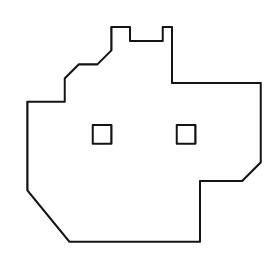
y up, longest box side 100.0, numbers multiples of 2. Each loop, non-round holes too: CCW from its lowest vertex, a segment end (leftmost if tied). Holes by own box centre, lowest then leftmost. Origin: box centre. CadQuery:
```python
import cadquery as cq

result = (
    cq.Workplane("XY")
    .moveTo(-32.0, -46.0)
    .lineTo(24.0, -46.0)
    .lineTo(24.0, -20.0)
    .lineTo(42.0, -20.0)
    .lineTo(50.0, -12.0)
    .lineTo(50.0, 22.0)
    .lineTo(12.0, 22.0)
    .lineTo(12.0, 46.0)
    .lineTo(8.0, 46.0)
    .lineTo(8.0, 40.0)
    .lineTo(-6.0, 40.0)
    .lineTo(-6.0, 46.0)
    .lineTo(-14.0, 46.0)
    .lineTo(-14.0, 36.0)
    .lineTo(-20.0, 30.0)
    .lineTo(-28.0, 30.0)
    .lineTo(-34.0, 24.0)
    .lineTo(-34.0, 14.0)
    .lineTo(-50.0, 14.0)
    .lineTo(-50.0, -24.0)
    .close()
    .moveTo(-22.0, -4.0)
    .lineTo(-14.0, -4.0)
    .lineTo(-14.0, 4.0)
    .lineTo(-22.0, 4.0)
    .close()
    .moveTo(14.0, -4.0)
    .lineTo(22.0, -4.0)
    .lineTo(22.0, 4.0)
    .lineTo(14.0, 4.0)
    .close()
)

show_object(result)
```